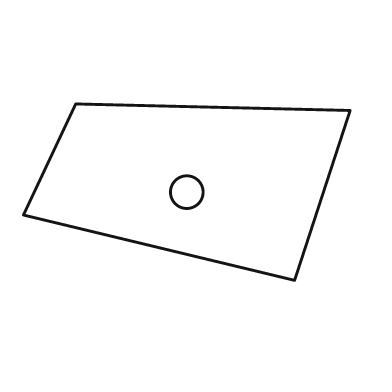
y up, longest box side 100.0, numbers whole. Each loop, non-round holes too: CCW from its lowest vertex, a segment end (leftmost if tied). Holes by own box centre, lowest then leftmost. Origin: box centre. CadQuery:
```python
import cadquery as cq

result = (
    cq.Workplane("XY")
    .moveTo(33.0, -27.0)
    .lineTo(50.0, 25.0)
    .lineTo(-34.0, 27.0)
    .lineTo(-50.0, -7.0)
    .close()
    .moveTo(0.0, 0.0)
    .circle(5.0)
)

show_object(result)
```